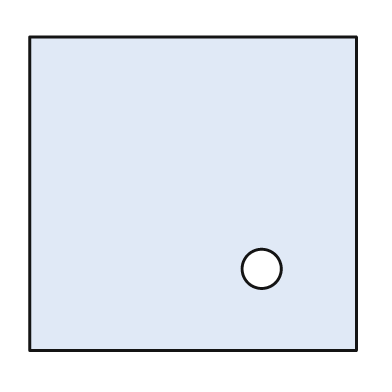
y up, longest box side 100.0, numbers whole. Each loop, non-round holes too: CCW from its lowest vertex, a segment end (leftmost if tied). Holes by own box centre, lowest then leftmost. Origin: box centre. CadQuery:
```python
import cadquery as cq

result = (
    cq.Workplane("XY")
    .moveTo(-50.0, -48.0)
    .lineTo(50.0, -48.0)
    .lineTo(50.0, 48.0)
    .lineTo(-50.0, 48.0)
    .close()
    .moveTo(21.0, -23.0)
    .circle(6.0)
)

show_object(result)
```